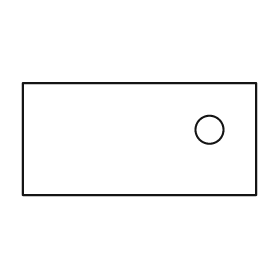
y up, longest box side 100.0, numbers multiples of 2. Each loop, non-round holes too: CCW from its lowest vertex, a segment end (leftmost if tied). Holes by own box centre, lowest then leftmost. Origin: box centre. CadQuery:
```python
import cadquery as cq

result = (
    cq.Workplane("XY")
    .moveTo(-50.0, -24.0)
    .lineTo(50.0, -24.0)
    .lineTo(50.0, 24.0)
    .lineTo(-50.0, 24.0)
    .close()
    .moveTo(30.0, 4.0)
    .circle(6.0)
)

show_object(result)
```